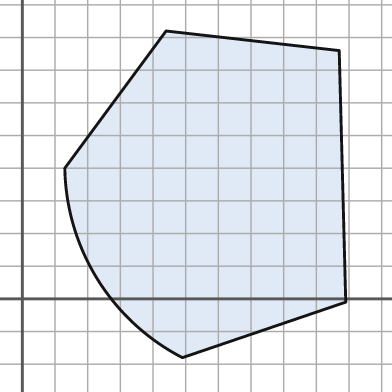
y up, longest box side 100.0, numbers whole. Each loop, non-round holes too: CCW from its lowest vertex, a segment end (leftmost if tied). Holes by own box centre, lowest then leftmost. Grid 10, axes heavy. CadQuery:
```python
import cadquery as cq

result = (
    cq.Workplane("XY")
    .moveTo(49.0, -18.0)
    .lineTo(99.0, -1.0)
    .lineTo(97.0, 76.0)
    .lineTo(44.0, 82.0)
    .lineTo(13.0, 40.0)
    .threePointArc((23.0, 6.0), (49.0, -18.0))
    .close()
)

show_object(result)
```